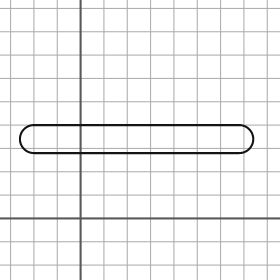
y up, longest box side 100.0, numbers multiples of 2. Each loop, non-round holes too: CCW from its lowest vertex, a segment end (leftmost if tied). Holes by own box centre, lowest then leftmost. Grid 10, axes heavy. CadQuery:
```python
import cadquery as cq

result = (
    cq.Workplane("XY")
    .moveTo(-20.0, 28.0)
    .lineTo(68.0, 28.0)
    .threePointArc((74.0, 34.0), (68.0, 40.0))
    .lineTo(-20.0, 40.0)
    .threePointArc((-26.0, 34.0), (-20.0, 28.0))
    .close()
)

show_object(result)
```